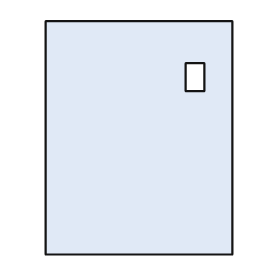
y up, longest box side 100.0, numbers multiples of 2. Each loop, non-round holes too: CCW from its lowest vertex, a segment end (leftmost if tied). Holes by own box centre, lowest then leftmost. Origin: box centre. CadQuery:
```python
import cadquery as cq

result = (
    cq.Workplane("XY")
    .moveTo(-40.0, -50.0)
    .lineTo(40.0, -50.0)
    .lineTo(40.0, 50.0)
    .lineTo(-40.0, 50.0)
    .close()
    .moveTo(20.0, 20.0)
    .lineTo(28.0, 20.0)
    .lineTo(28.0, 32.0)
    .lineTo(20.0, 32.0)
    .close()
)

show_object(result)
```